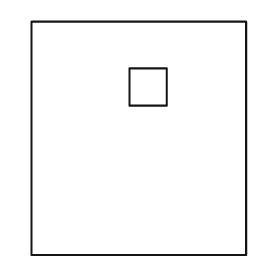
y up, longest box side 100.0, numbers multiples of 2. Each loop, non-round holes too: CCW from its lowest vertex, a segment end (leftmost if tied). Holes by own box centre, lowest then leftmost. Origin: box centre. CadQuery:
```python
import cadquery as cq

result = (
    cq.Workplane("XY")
    .moveTo(-46.0, -50.0)
    .lineTo(46.0, -50.0)
    .lineTo(46.0, 50.0)
    .lineTo(-46.0, 50.0)
    .close()
    .moveTo(-4.0, 14.0)
    .lineTo(12.0, 14.0)
    .lineTo(12.0, 30.0)
    .lineTo(-4.0, 30.0)
    .close()
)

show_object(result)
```